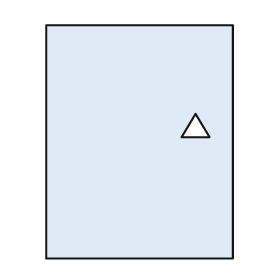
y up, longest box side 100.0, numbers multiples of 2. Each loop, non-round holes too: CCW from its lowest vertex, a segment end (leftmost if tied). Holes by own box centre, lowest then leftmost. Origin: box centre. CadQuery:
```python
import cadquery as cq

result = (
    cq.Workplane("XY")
    .moveTo(-40.0, -50.0)
    .lineTo(40.0, -50.0)
    .lineTo(40.0, 50.0)
    .lineTo(-40.0, 50.0)
    .close()
    .moveTo(18.0, 2.0)
    .lineTo(30.0, 2.0)
    .lineTo(24.0, 12.0)
    .close()
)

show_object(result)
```